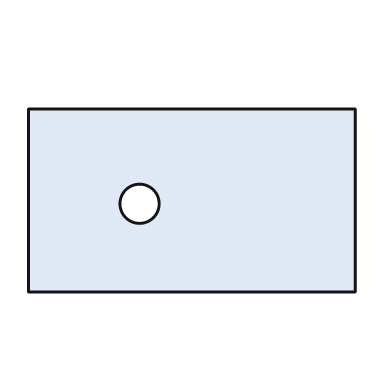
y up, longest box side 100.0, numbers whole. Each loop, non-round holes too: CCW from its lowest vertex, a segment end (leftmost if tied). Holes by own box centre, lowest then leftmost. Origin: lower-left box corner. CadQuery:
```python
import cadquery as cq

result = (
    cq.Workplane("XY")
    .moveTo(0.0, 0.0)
    .lineTo(100.0, 0.0)
    .lineTo(100.0, 56.0)
    .lineTo(0.0, 56.0)
    .close()
    .moveTo(34.0, 27.0)
    .circle(6.0)
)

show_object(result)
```